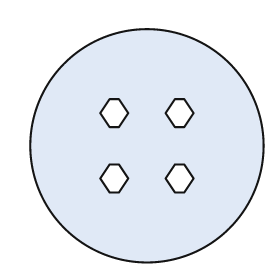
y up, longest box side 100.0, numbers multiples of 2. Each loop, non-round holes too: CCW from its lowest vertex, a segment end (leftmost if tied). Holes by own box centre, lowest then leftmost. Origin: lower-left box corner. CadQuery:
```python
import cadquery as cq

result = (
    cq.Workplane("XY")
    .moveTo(50.0, 50.0)
    .circle(50.0)
    .moveTo(34.0, 30.0)
    .lineTo(38.0, 30.0)
    .lineTo(42.0, 36.0)
    .lineTo(38.0, 42.0)
    .lineTo(34.0, 42.0)
    .lineTo(30.0, 36.0)
    .close()
    .moveTo(62.0, 30.0)
    .lineTo(66.0, 30.0)
    .lineTo(70.0, 36.0)
    .lineTo(66.0, 42.0)
    .lineTo(62.0, 42.0)
    .lineTo(58.0, 36.0)
    .close()
    .moveTo(34.0, 58.0)
    .lineTo(38.0, 58.0)
    .lineTo(42.0, 64.0)
    .lineTo(38.0, 70.0)
    .lineTo(34.0, 70.0)
    .lineTo(30.0, 64.0)
    .close()
    .moveTo(62.0, 58.0)
    .lineTo(66.0, 58.0)
    .lineTo(70.0, 64.0)
    .lineTo(66.0, 70.0)
    .lineTo(62.0, 70.0)
    .lineTo(58.0, 64.0)
    .close()
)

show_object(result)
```